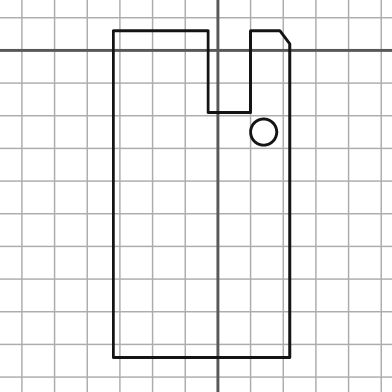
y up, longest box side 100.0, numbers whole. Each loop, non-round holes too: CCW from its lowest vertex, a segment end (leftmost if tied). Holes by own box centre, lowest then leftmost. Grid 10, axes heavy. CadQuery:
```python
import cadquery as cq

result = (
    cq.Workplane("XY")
    .moveTo(-32.0, -94.0)
    .lineTo(22.0, -94.0)
    .lineTo(22.0, 2.0)
    .lineTo(19.0, 6.0)
    .lineTo(10.0, 6.0)
    .lineTo(10.0, -19.0)
    .lineTo(-3.0, -19.0)
    .lineTo(-3.0, 6.0)
    .lineTo(-32.0, 6.0)
    .close()
    .moveTo(14.0, -25.0)
    .circle(4.0)
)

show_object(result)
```